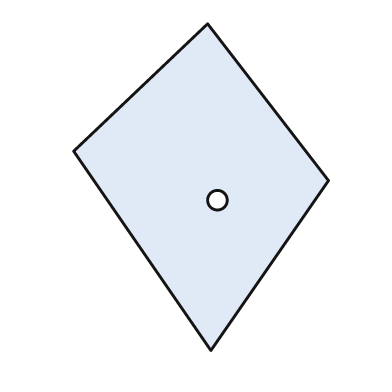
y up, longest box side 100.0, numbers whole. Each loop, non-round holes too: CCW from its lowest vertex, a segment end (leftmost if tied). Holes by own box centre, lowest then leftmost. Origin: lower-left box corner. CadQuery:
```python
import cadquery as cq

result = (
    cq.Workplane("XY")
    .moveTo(42.0, 0.0)
    .lineTo(78.0, 52.0)
    .lineTo(41.0, 100.0)
    .lineTo(0.0, 61.0)
    .close()
    .moveTo(44.0, 46.0)
    .circle(3.0)
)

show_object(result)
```